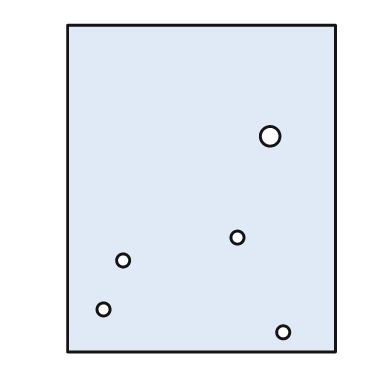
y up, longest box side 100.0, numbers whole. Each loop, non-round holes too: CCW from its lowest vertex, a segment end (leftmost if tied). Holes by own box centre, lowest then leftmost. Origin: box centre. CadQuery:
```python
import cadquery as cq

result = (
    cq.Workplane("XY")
    .moveTo(-41.0, -50.0)
    .lineTo(41.0, -50.0)
    .lineTo(41.0, 50.0)
    .lineTo(-41.0, 50.0)
    .close()
    .moveTo(25.0, -44.0)
    .circle(2.0)
    .moveTo(-30.0, -37.0)
    .circle(2.0)
    .moveTo(-24.0, -22.0)
    .circle(2.0)
    .moveTo(11.0, -15.0)
    .circle(2.0)
    .moveTo(21.0, 16.0)
    .circle(3.0)
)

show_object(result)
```